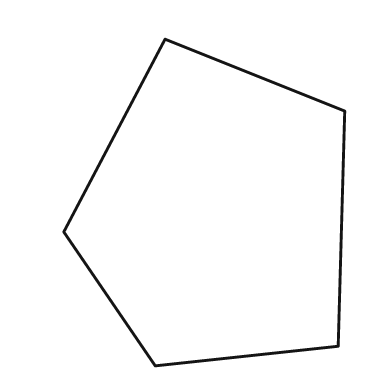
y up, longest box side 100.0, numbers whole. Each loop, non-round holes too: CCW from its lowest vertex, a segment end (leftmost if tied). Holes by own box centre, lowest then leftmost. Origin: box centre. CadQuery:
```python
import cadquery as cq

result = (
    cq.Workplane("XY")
    .moveTo(-15.0, -50.0)
    .lineTo(41.0, -44.0)
    .lineTo(43.0, 28.0)
    .lineTo(-12.0, 50.0)
    .lineTo(-43.0, -9.0)
    .close()
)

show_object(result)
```